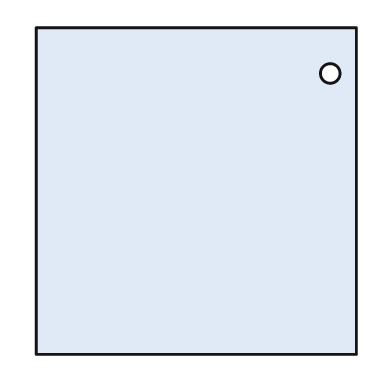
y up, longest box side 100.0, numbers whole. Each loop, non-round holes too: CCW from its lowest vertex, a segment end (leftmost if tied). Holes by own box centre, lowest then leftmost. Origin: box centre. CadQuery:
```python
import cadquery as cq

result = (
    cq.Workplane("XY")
    .moveTo(-49.0, -50.0)
    .lineTo(49.0, -50.0)
    .lineTo(49.0, 50.0)
    .lineTo(-49.0, 50.0)
    .close()
    .moveTo(41.0, 36.0)
    .circle(3.0)
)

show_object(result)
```